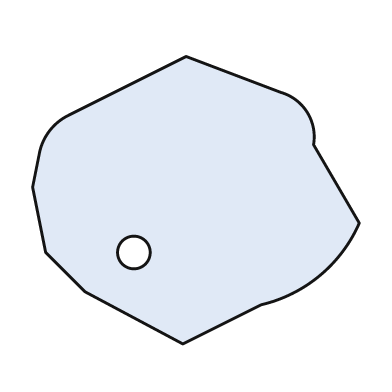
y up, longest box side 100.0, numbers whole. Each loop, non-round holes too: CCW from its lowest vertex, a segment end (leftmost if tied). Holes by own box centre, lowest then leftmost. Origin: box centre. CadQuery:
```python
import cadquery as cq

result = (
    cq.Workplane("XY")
    .moveTo(-4.0, -44.0)
    .lineTo(20.0, -32.0)
    .threePointArc((38.0, -23.0), (50.0, -7.0))
    .lineTo(36.0, 17.0)
    .threePointArc((34.0, 27.0), (26.0, 33.0))
    .lineTo(-3.0, 44.0)
    .lineTo(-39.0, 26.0)
    .threePointArc((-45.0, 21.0), (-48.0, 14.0))
    .lineTo(-50.0, 4.0)
    .lineTo(-46.0, -16.0)
    .lineTo(-34.0, -28.0)
    .close()
    .moveTo(-19.0, -16.0)
    .circle(5.0)
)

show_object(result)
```